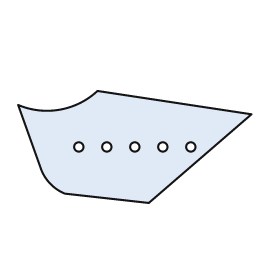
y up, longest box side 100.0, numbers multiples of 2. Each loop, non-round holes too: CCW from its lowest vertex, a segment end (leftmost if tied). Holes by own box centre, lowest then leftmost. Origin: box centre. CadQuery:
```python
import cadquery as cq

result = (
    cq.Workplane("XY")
    .moveTo(6.0, -24.0)
    .lineTo(50.0, 14.0)
    .lineTo(-16.0, 24.0)
    .threePointArc((-32.0, 16.0), (-50.0, 18.0))
    .lineTo(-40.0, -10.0)
    .threePointArc((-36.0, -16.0), (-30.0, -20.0))
    .close()
    .moveTo(-24.0, 0.0)
    .circle(2.0)
    .moveTo(-12.0, 0.0)
    .circle(2.0)
    .moveTo(0.0, 0.0)
    .circle(2.0)
    .moveTo(12.0, 0.0)
    .circle(2.0)
    .moveTo(24.0, 0.0)
    .circle(2.0)
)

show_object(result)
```